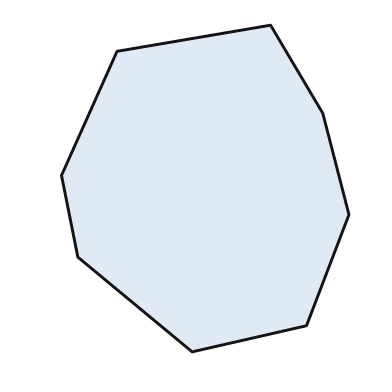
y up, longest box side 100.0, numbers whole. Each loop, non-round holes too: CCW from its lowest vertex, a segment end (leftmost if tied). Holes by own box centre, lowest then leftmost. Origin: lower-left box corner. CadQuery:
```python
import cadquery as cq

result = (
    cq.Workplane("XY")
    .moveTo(40.0, 0.0)
    .lineTo(75.0, 8.0)
    .lineTo(88.0, 42.0)
    .lineTo(80.0, 73.0)
    .lineTo(64.0, 100.0)
    .lineTo(17.0, 92.0)
    .lineTo(0.0, 54.0)
    .lineTo(5.0, 29.0)
    .close()
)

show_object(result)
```